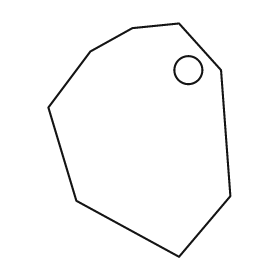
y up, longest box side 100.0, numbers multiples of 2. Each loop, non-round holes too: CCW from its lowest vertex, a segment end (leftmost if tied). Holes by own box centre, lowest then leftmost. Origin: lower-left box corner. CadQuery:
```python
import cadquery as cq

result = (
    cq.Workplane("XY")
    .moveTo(56.0, 0.0)
    .lineTo(78.0, 26.0)
    .lineTo(74.0, 80.0)
    .lineTo(56.0, 100.0)
    .lineTo(36.0, 98.0)
    .lineTo(18.0, 88.0)
    .lineTo(0.0, 64.0)
    .lineTo(12.0, 24.0)
    .close()
    .moveTo(60.0, 80.0)
    .circle(6.0)
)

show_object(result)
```